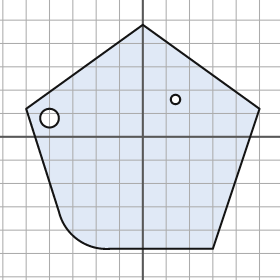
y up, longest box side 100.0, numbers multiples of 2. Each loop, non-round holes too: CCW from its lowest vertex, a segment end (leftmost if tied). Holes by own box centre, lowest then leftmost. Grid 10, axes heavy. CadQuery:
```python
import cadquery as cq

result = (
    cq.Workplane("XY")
    .moveTo(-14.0, -48.0)
    .lineTo(30.0, -48.0)
    .lineTo(50.0, 12.0)
    .lineTo(0.0, 48.0)
    .lineTo(-50.0, 12.0)
    .lineTo(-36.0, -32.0)
    .threePointArc((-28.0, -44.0), (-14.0, -48.0))
    .close()
    .moveTo(-40.0, 8.0)
    .circle(4.0)
    .moveTo(14.0, 16.0)
    .circle(2.0)
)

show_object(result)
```